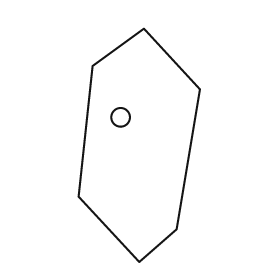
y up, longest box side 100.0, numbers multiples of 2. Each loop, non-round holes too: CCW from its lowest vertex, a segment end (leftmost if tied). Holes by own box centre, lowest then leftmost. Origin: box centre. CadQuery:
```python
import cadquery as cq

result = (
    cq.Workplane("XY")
    .moveTo(0.0, -50.0)
    .lineTo(16.0, -36.0)
    .lineTo(26.0, 24.0)
    .lineTo(2.0, 50.0)
    .lineTo(-20.0, 34.0)
    .lineTo(-26.0, -22.0)
    .close()
    .moveTo(-8.0, 12.0)
    .circle(4.0)
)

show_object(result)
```